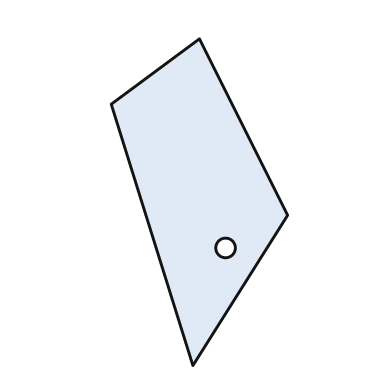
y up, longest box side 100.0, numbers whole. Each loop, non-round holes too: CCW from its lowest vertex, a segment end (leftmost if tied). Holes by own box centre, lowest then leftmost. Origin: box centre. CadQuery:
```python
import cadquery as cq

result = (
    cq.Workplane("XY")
    .moveTo(-2.0, -50.0)
    .lineTo(27.0, -4.0)
    .lineTo(0.0, 50.0)
    .lineTo(-27.0, 30.0)
    .close()
    .moveTo(8.0, -14.0)
    .circle(3.0)
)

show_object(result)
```